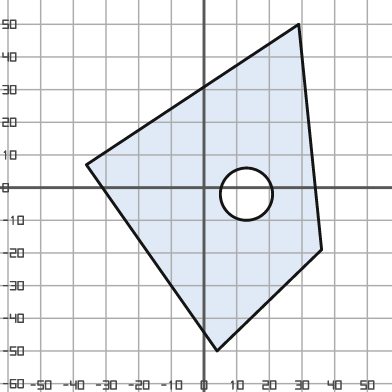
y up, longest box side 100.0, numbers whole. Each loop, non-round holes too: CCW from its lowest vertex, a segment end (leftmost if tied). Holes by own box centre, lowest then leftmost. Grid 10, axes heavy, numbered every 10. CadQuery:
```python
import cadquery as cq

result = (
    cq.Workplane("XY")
    .moveTo(4.0, -50.0)
    .lineTo(36.0, -19.0)
    .lineTo(29.0, 50.0)
    .lineTo(-36.0, 7.0)
    .close()
    .moveTo(13.0, -2.0)
    .circle(8.0)
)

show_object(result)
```